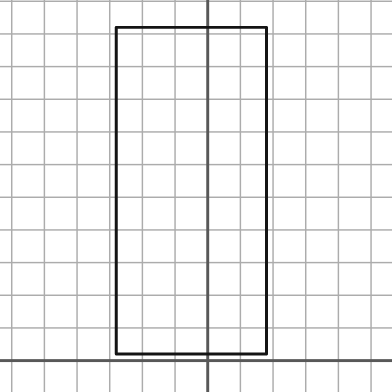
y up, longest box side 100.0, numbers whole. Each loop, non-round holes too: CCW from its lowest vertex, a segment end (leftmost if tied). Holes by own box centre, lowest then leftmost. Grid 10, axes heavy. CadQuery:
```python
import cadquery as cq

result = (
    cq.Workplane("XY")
    .moveTo(-28.0, 2.0)
    .lineTo(18.0, 2.0)
    .lineTo(18.0, 102.0)
    .lineTo(-28.0, 102.0)
    .close()
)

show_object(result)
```